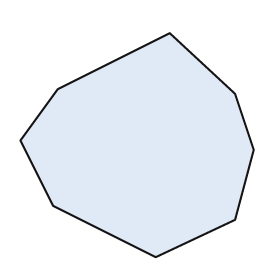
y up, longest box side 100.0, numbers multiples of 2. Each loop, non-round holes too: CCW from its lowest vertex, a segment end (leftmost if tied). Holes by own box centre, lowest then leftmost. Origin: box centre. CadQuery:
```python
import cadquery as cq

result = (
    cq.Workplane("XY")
    .moveTo(8.0, -48.0)
    .lineTo(42.0, -32.0)
    .lineTo(50.0, -2.0)
    .lineTo(42.0, 22.0)
    .lineTo(14.0, 48.0)
    .lineTo(-34.0, 24.0)
    .lineTo(-50.0, 2.0)
    .lineTo(-36.0, -26.0)
    .close()
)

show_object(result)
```